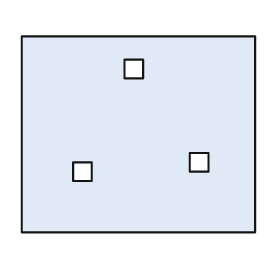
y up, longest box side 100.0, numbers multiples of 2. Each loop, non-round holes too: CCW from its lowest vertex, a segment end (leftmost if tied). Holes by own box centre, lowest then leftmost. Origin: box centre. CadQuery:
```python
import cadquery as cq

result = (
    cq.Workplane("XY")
    .moveTo(-50.0, -42.0)
    .lineTo(50.0, -42.0)
    .lineTo(50.0, 42.0)
    .lineTo(-50.0, 42.0)
    .close()
    .moveTo(-28.0, -20.0)
    .lineTo(-20.0, -20.0)
    .lineTo(-20.0, -12.0)
    .lineTo(-28.0, -12.0)
    .close()
    .moveTo(22.0, -16.0)
    .lineTo(30.0, -16.0)
    .lineTo(30.0, -8.0)
    .lineTo(22.0, -8.0)
    .close()
    .moveTo(-6.0, 24.0)
    .lineTo(2.0, 24.0)
    .lineTo(2.0, 32.0)
    .lineTo(-6.0, 32.0)
    .close()
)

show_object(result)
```